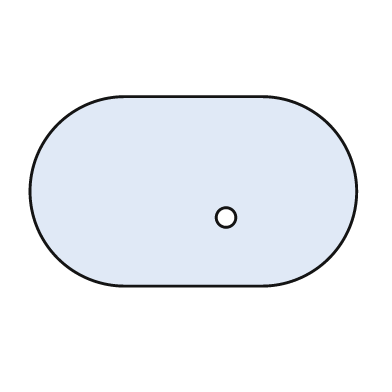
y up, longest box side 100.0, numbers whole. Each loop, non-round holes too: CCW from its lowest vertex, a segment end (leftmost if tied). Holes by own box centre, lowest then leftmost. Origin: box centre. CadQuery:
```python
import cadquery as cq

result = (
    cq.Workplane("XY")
    .moveTo(-21.0, -29.0)
    .lineTo(21.0, -29.0)
    .threePointArc((50.0, 0.0), (21.0, 29.0))
    .lineTo(-21.0, 29.0)
    .threePointArc((-50.0, 0.0), (-21.0, -29.0))
    .close()
    .moveTo(10.0, -8.0)
    .circle(3.0)
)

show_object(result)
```